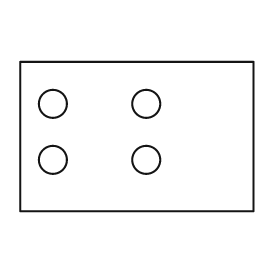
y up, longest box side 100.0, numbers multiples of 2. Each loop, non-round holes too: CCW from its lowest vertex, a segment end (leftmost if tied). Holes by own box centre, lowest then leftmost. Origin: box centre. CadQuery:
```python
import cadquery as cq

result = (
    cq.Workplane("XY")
    .moveTo(-50.0, -32.0)
    .lineTo(50.0, -32.0)
    .lineTo(50.0, 32.0)
    .lineTo(-50.0, 32.0)
    .close()
    .moveTo(-36.0, -10.0)
    .circle(6.0)
    .moveTo(4.0, -10.0)
    .circle(6.0)
    .moveTo(-36.0, 14.0)
    .circle(6.0)
    .moveTo(4.0, 14.0)
    .circle(6.0)
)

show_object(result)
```